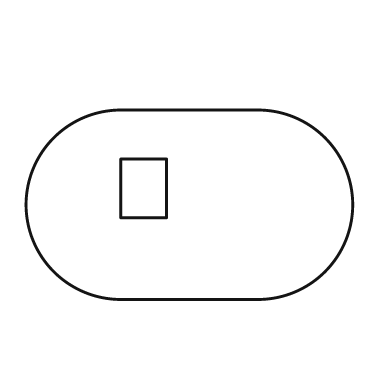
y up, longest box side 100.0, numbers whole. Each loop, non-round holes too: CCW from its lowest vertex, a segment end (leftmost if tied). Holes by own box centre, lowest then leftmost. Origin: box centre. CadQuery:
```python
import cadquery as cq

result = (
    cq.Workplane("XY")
    .moveTo(-21.0, -29.0)
    .lineTo(21.0, -29.0)
    .threePointArc((50.0, 0.0), (21.0, 29.0))
    .lineTo(-21.0, 29.0)
    .threePointArc((-50.0, 0.0), (-21.0, -29.0))
    .close()
    .moveTo(-21.0, -4.0)
    .lineTo(-7.0, -4.0)
    .lineTo(-7.0, 14.0)
    .lineTo(-21.0, 14.0)
    .close()
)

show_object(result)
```